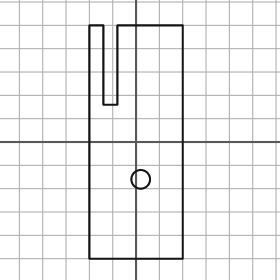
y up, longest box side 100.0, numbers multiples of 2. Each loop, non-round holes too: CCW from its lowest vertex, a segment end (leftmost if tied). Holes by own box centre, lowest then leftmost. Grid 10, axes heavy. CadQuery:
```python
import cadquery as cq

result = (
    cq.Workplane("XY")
    .moveTo(-20.0, -50.0)
    .lineTo(20.0, -50.0)
    .lineTo(20.0, 50.0)
    .lineTo(-8.0, 50.0)
    .lineTo(-8.0, 16.0)
    .lineTo(-14.0, 16.0)
    .lineTo(-14.0, 50.0)
    .lineTo(-20.0, 50.0)
    .close()
    .moveTo(2.0, -16.0)
    .circle(4.0)
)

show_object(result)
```